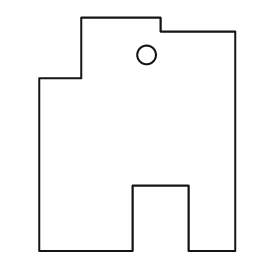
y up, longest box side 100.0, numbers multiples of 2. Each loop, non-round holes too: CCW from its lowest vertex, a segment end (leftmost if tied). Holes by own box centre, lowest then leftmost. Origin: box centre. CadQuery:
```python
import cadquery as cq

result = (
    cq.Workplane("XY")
    .moveTo(-42.0, -50.0)
    .lineTo(-2.0, -50.0)
    .lineTo(-2.0, -22.0)
    .lineTo(22.0, -22.0)
    .lineTo(22.0, -50.0)
    .lineTo(42.0, -50.0)
    .lineTo(42.0, 44.0)
    .lineTo(10.0, 44.0)
    .lineTo(10.0, 50.0)
    .lineTo(-24.0, 50.0)
    .lineTo(-24.0, 24.0)
    .lineTo(-42.0, 24.0)
    .close()
    .moveTo(4.0, 34.0)
    .circle(4.0)
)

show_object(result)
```